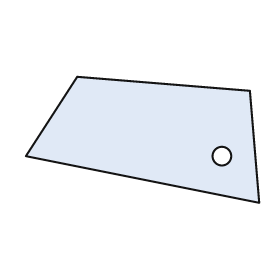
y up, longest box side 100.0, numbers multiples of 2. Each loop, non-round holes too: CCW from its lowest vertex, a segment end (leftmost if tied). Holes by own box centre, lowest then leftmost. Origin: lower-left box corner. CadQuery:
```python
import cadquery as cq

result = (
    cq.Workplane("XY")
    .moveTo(100.0, 0.0)
    .lineTo(96.0, 48.0)
    .lineTo(22.0, 54.0)
    .lineTo(0.0, 20.0)
    .close()
    .moveTo(84.0, 20.0)
    .circle(4.0)
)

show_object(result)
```